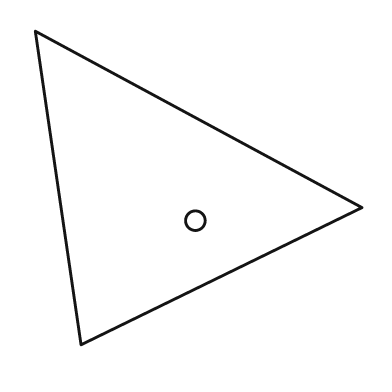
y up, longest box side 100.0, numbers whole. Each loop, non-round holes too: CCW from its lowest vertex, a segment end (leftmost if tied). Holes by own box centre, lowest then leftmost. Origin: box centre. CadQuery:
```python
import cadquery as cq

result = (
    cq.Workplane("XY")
    .moveTo(-36.0, -48.0)
    .lineTo(50.0, -6.0)
    .lineTo(-50.0, 48.0)
    .close()
    .moveTo(-1.0, -10.0)
    .circle(3.0)
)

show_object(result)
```